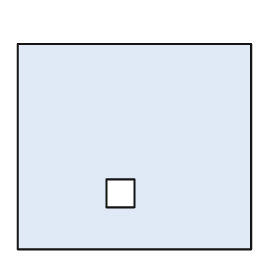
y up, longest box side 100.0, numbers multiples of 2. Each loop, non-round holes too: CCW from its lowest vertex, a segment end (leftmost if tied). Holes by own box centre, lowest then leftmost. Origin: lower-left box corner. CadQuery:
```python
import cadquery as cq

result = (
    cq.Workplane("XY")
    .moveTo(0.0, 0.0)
    .lineTo(100.0, 0.0)
    .lineTo(100.0, 88.0)
    .lineTo(0.0, 88.0)
    .close()
    .moveTo(38.0, 18.0)
    .lineTo(50.0, 18.0)
    .lineTo(50.0, 30.0)
    .lineTo(38.0, 30.0)
    .close()
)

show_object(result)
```